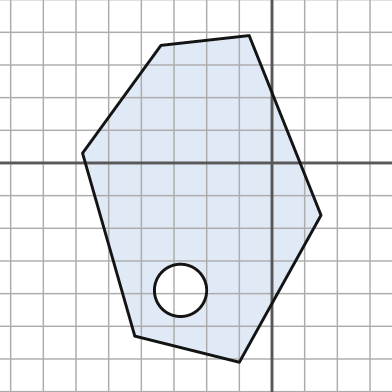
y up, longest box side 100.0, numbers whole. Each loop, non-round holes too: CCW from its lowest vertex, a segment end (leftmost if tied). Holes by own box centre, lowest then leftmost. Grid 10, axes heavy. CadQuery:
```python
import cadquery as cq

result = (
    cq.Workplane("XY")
    .moveTo(-10.0, -61.0)
    .lineTo(15.0, -16.0)
    .lineTo(-7.0, 39.0)
    .lineTo(-34.0, 36.0)
    .lineTo(-58.0, 3.0)
    .lineTo(-42.0, -53.0)
    .close()
    .moveTo(-28.0, -39.0)
    .circle(8.0)
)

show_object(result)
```